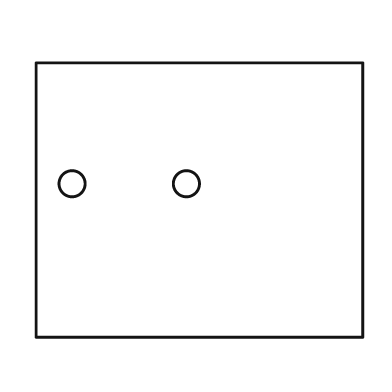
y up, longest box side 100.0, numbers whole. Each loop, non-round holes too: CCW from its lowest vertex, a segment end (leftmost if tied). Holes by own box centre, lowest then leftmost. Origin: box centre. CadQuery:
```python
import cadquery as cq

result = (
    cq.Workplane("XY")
    .moveTo(-50.0, -42.0)
    .lineTo(50.0, -42.0)
    .lineTo(50.0, 42.0)
    .lineTo(-50.0, 42.0)
    .close()
    .moveTo(-39.0, 5.0)
    .circle(4.0)
    .moveTo(-4.0, 5.0)
    .circle(4.0)
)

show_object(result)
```